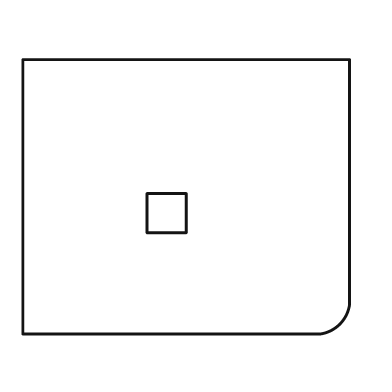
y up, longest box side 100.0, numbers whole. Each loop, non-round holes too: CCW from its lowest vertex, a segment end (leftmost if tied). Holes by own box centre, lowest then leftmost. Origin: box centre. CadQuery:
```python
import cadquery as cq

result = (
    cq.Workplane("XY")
    .moveTo(-50.0, -42.0)
    .lineTo(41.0, -42.0)
    .threePointArc((47.0, -39.0), (50.0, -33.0))
    .lineTo(50.0, 42.0)
    .lineTo(-50.0, 42.0)
    .close()
    .moveTo(-12.0, -11.0)
    .lineTo(0.0, -11.0)
    .lineTo(0.0, 1.0)
    .lineTo(-12.0, 1.0)
    .close()
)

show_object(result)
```